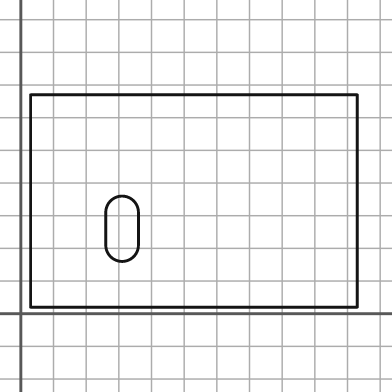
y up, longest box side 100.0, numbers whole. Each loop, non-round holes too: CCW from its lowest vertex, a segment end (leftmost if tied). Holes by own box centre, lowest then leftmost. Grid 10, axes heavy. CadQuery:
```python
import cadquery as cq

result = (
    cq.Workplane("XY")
    .moveTo(3.0, 2.0)
    .lineTo(103.0, 2.0)
    .lineTo(103.0, 67.0)
    .lineTo(3.0, 67.0)
    .close()
    .moveTo(26.0, 21.0)
    .threePointArc((31.0, 16.0), (36.0, 21.0))
    .lineTo(36.0, 31.0)
    .threePointArc((31.0, 36.0), (26.0, 31.0))
    .close()
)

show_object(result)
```